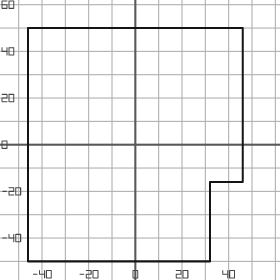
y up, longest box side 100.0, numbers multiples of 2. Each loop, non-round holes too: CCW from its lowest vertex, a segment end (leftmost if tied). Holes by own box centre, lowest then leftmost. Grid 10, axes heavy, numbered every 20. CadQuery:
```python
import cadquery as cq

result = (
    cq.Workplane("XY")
    .moveTo(-46.0, -50.0)
    .lineTo(32.0, -50.0)
    .lineTo(32.0, -16.0)
    .lineTo(46.0, -16.0)
    .lineTo(46.0, 50.0)
    .lineTo(-46.0, 50.0)
    .close()
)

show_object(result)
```